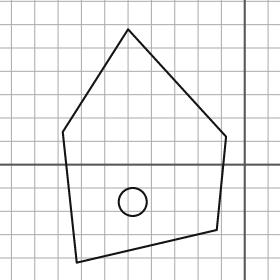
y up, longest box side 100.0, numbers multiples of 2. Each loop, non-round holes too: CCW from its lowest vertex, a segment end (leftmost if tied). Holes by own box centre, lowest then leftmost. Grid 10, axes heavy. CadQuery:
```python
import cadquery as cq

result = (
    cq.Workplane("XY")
    .moveTo(-72.0, -42.0)
    .lineTo(-12.0, -28.0)
    .lineTo(-8.0, 12.0)
    .lineTo(-50.0, 58.0)
    .lineTo(-78.0, 14.0)
    .close()
    .moveTo(-48.0, -16.0)
    .circle(6.0)
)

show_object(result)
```